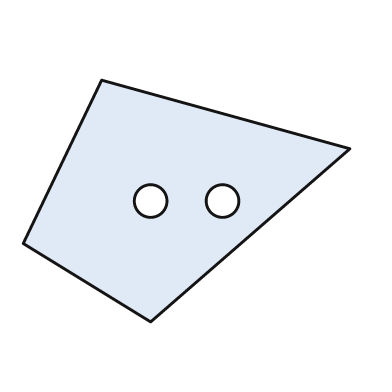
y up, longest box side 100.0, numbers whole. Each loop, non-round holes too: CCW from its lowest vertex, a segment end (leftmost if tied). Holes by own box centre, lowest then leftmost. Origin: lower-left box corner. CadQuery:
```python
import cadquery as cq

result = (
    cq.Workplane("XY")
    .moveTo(39.0, 0.0)
    .lineTo(100.0, 53.0)
    .lineTo(24.0, 74.0)
    .lineTo(0.0, 24.0)
    .close()
    .moveTo(39.0, 37.0)
    .circle(5.0)
    .moveTo(61.0, 37.0)
    .circle(5.0)
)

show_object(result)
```